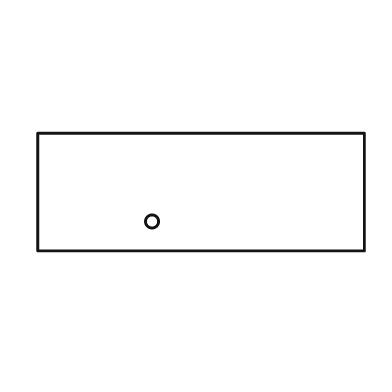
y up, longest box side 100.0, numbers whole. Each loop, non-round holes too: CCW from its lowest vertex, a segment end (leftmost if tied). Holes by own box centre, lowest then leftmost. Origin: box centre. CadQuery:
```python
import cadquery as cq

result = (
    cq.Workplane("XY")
    .moveTo(-50.0, -18.0)
    .lineTo(50.0, -18.0)
    .lineTo(50.0, 18.0)
    .lineTo(-50.0, 18.0)
    .close()
    .moveTo(-15.0, -9.0)
    .circle(2.0)
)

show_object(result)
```